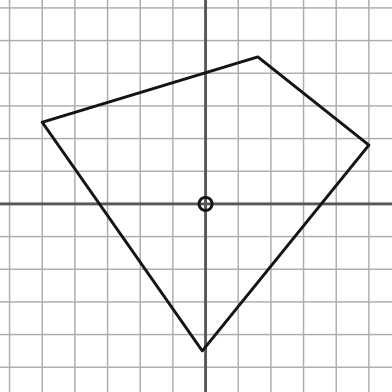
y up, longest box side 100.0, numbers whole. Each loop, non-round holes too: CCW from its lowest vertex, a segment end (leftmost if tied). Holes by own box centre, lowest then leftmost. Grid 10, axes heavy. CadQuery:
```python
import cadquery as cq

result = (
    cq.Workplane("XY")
    .moveTo(-1.0, -45.0)
    .lineTo(50.0, 18.0)
    .lineTo(16.0, 45.0)
    .lineTo(-50.0, 25.0)
    .close()
    .moveTo(0.0, 0.0)
    .circle(2.0)
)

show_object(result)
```